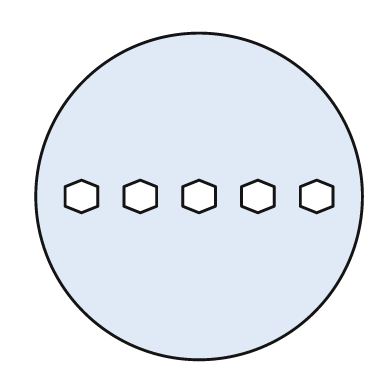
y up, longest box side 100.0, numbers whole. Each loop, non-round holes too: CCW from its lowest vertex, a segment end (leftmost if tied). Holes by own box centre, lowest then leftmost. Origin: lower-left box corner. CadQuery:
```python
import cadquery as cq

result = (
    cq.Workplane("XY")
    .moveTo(50.0, 50.0)
    .circle(50.0)
    .moveTo(14.0, 45.0)
    .lineTo(19.0, 47.0)
    .lineTo(19.0, 53.0)
    .lineTo(14.0, 55.0)
    .lineTo(9.0, 53.0)
    .lineTo(9.0, 47.0)
    .close()
    .moveTo(32.0, 45.0)
    .lineTo(37.0, 47.0)
    .lineTo(37.0, 53.0)
    .lineTo(32.0, 55.0)
    .lineTo(27.0, 53.0)
    .lineTo(27.0, 47.0)
    .close()
    .moveTo(50.0, 45.0)
    .lineTo(55.0, 47.0)
    .lineTo(55.0, 53.0)
    .lineTo(50.0, 55.0)
    .lineTo(45.0, 53.0)
    .lineTo(45.0, 47.0)
    .close()
    .moveTo(68.0, 45.0)
    .lineTo(73.0, 47.0)
    .lineTo(73.0, 53.0)
    .lineTo(68.0, 55.0)
    .lineTo(63.0, 53.0)
    .lineTo(63.0, 47.0)
    .close()
    .moveTo(86.0, 45.0)
    .lineTo(91.0, 47.0)
    .lineTo(91.0, 53.0)
    .lineTo(86.0, 55.0)
    .lineTo(81.0, 53.0)
    .lineTo(81.0, 47.0)
    .close()
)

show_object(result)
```